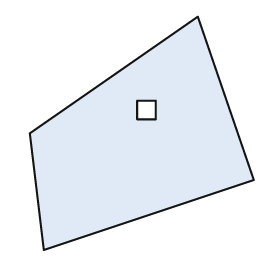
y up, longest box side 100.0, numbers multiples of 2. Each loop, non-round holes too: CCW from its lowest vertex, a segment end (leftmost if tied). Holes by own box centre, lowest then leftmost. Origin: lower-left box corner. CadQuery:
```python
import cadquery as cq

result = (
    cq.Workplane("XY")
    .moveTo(6.0, 0.0)
    .lineTo(96.0, 30.0)
    .lineTo(72.0, 100.0)
    .lineTo(0.0, 50.0)
    .close()
    .moveTo(46.0, 56.0)
    .lineTo(54.0, 56.0)
    .lineTo(54.0, 64.0)
    .lineTo(46.0, 64.0)
    .close()
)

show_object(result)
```